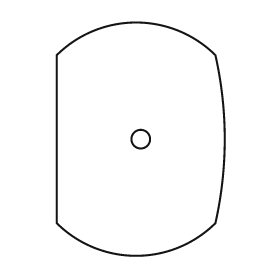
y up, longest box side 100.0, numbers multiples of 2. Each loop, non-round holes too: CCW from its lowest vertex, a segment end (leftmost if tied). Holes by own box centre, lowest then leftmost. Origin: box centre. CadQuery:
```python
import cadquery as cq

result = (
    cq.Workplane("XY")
    .moveTo(-36.0, -36.0)
    .threePointArc((-2.0, -50.0), (32.0, -36.0))
    .threePointArc((36.0, 0.0), (32.0, 36.0))
    .threePointArc((-2.0, 50.0), (-36.0, 36.0))
    .close()
    .moveTo(0.0, 0.0)
    .circle(4.0)
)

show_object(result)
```